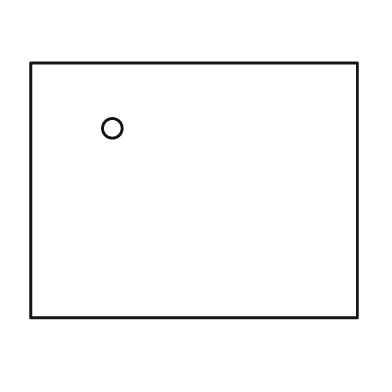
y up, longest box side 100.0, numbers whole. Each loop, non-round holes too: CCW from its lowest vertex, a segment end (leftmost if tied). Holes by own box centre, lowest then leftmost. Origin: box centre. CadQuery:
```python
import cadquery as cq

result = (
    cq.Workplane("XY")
    .moveTo(-50.0, -39.0)
    .lineTo(50.0, -39.0)
    .lineTo(50.0, 39.0)
    .lineTo(-50.0, 39.0)
    .close()
    .moveTo(-25.0, 19.0)
    .circle(3.0)
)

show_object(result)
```